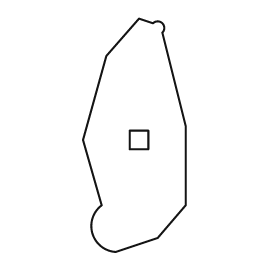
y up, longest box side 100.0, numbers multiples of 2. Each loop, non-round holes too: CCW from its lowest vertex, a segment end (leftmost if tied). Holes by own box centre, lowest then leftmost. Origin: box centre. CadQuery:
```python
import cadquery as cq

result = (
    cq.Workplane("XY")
    .moveTo(-8.0, -50.0)
    .lineTo(10.0, -44.0)
    .lineTo(22.0, -30.0)
    .lineTo(22.0, 4.0)
    .lineTo(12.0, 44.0)
    .threePointArc((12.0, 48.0), (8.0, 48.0))
    .lineTo(2.0, 50.0)
    .lineTo(-12.0, 34.0)
    .lineTo(-22.0, -2.0)
    .lineTo(-14.0, -30.0)
    .threePointArc((-18.0, -42.0), (-8.0, -50.0))
    .close()
    .moveTo(-2.0, -6.0)
    .lineTo(6.0, -6.0)
    .lineTo(6.0, 2.0)
    .lineTo(-2.0, 2.0)
    .close()
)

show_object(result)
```